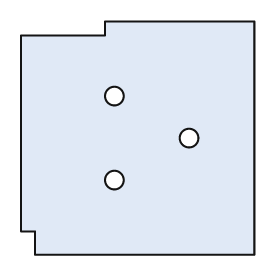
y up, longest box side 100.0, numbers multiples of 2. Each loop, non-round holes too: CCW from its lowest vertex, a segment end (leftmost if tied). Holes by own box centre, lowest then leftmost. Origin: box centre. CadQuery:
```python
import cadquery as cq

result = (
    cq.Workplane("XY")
    .moveTo(-44.0, -50.0)
    .lineTo(50.0, -50.0)
    .lineTo(50.0, 50.0)
    .lineTo(-14.0, 50.0)
    .lineTo(-14.0, 44.0)
    .lineTo(-50.0, 44.0)
    .lineTo(-50.0, -40.0)
    .lineTo(-44.0, -40.0)
    .close()
    .moveTo(-10.0, -18.0)
    .circle(4.0)
    .moveTo(22.0, 0.0)
    .circle(4.0)
    .moveTo(-10.0, 18.0)
    .circle(4.0)
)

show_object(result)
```